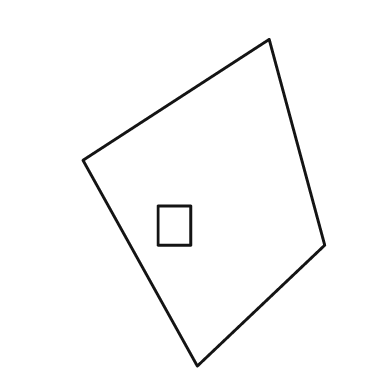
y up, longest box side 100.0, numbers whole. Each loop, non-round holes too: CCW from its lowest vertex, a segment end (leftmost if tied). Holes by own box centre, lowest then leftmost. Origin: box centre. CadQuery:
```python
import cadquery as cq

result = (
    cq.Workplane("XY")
    .moveTo(-2.0, -50.0)
    .lineTo(37.0, -13.0)
    .lineTo(20.0, 50.0)
    .lineTo(-37.0, 13.0)
    .close()
    .moveTo(-14.0, -13.0)
    .lineTo(-4.0, -13.0)
    .lineTo(-4.0, -1.0)
    .lineTo(-14.0, -1.0)
    .close()
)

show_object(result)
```